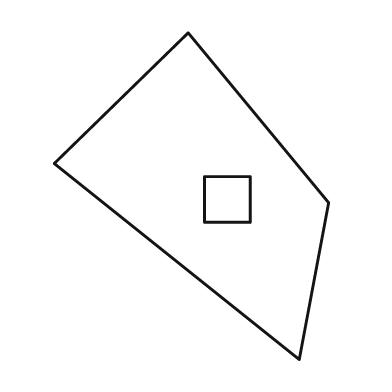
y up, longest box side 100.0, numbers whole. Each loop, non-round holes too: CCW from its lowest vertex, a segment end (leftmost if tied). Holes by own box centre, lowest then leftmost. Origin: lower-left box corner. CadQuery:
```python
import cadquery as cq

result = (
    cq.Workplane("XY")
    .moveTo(75.0, 0.0)
    .lineTo(84.0, 48.0)
    .lineTo(41.0, 100.0)
    .lineTo(0.0, 60.0)
    .close()
    .moveTo(46.0, 42.0)
    .lineTo(60.0, 42.0)
    .lineTo(60.0, 56.0)
    .lineTo(46.0, 56.0)
    .close()
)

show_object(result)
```